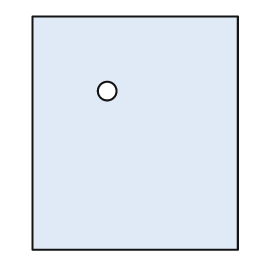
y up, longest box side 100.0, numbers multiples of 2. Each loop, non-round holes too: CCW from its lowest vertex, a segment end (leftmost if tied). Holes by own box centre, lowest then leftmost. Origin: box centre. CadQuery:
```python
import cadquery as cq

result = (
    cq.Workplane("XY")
    .moveTo(-44.0, -50.0)
    .lineTo(44.0, -50.0)
    .lineTo(44.0, 50.0)
    .lineTo(-44.0, 50.0)
    .close()
    .moveTo(-12.0, 18.0)
    .circle(4.0)
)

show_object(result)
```